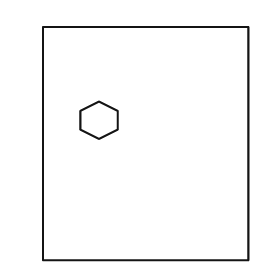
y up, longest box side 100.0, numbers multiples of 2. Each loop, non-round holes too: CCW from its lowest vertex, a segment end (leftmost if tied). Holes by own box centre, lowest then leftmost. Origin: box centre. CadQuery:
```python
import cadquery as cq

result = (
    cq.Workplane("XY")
    .moveTo(-44.0, -50.0)
    .lineTo(44.0, -50.0)
    .lineTo(44.0, 50.0)
    .lineTo(-44.0, 50.0)
    .close()
    .moveTo(-20.0, 2.0)
    .lineTo(-12.0, 6.0)
    .lineTo(-12.0, 14.0)
    .lineTo(-20.0, 18.0)
    .lineTo(-28.0, 14.0)
    .lineTo(-28.0, 6.0)
    .close()
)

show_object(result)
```